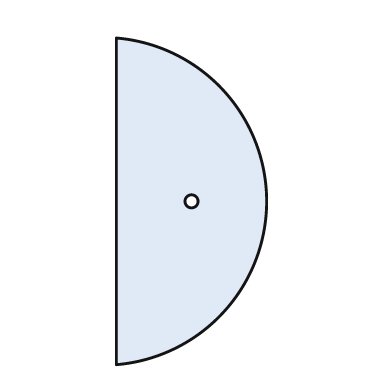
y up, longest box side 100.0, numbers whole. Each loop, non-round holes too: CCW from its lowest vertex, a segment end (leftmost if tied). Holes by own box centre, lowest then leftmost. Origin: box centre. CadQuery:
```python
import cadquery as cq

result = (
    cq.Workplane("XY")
    .moveTo(-23.0, -50.0)
    .threePointArc((23.0, 0.0), (-23.0, 50.0))
    .close()
    .moveTo(0.0, 0.0)
    .circle(2.0)
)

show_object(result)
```